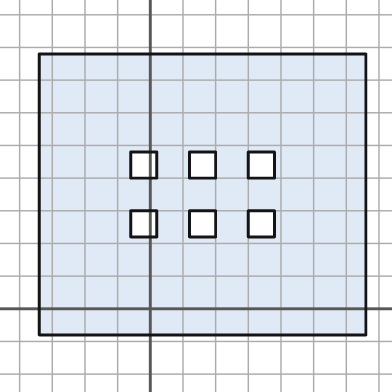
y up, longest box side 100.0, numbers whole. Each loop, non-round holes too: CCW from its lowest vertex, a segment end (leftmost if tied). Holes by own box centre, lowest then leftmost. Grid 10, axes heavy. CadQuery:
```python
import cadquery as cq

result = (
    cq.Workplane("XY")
    .moveTo(-34.0, -8.0)
    .lineTo(66.0, -8.0)
    .lineTo(66.0, 78.0)
    .lineTo(-34.0, 78.0)
    .close()
    .moveTo(-6.0, 22.0)
    .lineTo(2.0, 22.0)
    .lineTo(2.0, 30.0)
    .lineTo(-6.0, 30.0)
    .close()
    .moveTo(12.0, 22.0)
    .lineTo(20.0, 22.0)
    .lineTo(20.0, 30.0)
    .lineTo(12.0, 30.0)
    .close()
    .moveTo(30.0, 22.0)
    .lineTo(38.0, 22.0)
    .lineTo(38.0, 30.0)
    .lineTo(30.0, 30.0)
    .close()
    .moveTo(-6.0, 40.0)
    .lineTo(2.0, 40.0)
    .lineTo(2.0, 48.0)
    .lineTo(-6.0, 48.0)
    .close()
    .moveTo(12.0, 40.0)
    .lineTo(20.0, 40.0)
    .lineTo(20.0, 48.0)
    .lineTo(12.0, 48.0)
    .close()
    .moveTo(30.0, 40.0)
    .lineTo(38.0, 40.0)
    .lineTo(38.0, 48.0)
    .lineTo(30.0, 48.0)
    .close()
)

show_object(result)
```